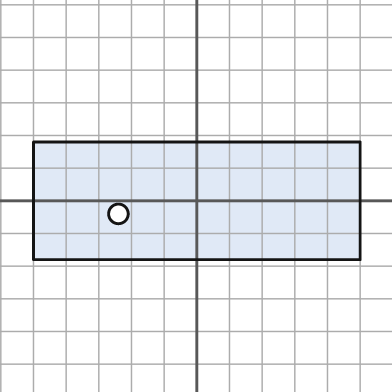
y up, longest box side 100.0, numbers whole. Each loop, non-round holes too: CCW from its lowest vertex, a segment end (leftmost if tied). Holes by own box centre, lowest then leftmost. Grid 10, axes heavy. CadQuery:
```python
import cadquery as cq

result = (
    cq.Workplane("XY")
    .moveTo(-50.0, -18.0)
    .lineTo(50.0, -18.0)
    .lineTo(50.0, 18.0)
    .lineTo(-50.0, 18.0)
    .close()
    .moveTo(-24.0, -4.0)
    .circle(3.0)
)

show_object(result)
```